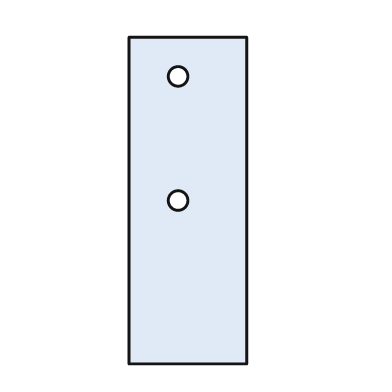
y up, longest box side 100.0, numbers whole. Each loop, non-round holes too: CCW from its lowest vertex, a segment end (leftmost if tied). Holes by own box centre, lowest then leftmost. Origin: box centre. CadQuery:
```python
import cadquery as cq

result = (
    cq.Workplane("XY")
    .moveTo(-18.0, -50.0)
    .lineTo(18.0, -50.0)
    .lineTo(18.0, 50.0)
    .lineTo(-18.0, 50.0)
    .close()
    .moveTo(-3.0, 0.0)
    .circle(3.0)
    .moveTo(-3.0, 38.0)
    .circle(3.0)
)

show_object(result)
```